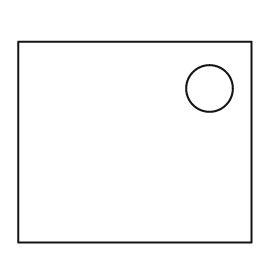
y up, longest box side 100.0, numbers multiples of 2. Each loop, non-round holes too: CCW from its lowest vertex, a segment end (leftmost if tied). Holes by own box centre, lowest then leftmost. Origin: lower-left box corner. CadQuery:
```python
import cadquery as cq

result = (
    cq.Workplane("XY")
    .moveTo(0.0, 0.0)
    .lineTo(100.0, 0.0)
    .lineTo(100.0, 86.0)
    .lineTo(0.0, 86.0)
    .close()
    .moveTo(82.0, 66.0)
    .circle(10.0)
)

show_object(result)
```